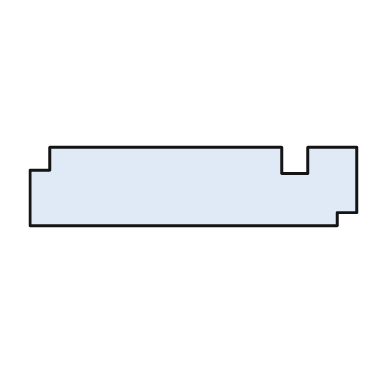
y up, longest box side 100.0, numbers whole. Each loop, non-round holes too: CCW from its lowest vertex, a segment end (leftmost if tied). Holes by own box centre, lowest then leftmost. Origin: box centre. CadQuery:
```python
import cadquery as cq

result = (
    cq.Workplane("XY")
    .moveTo(-50.0, -12.0)
    .lineTo(44.0, -12.0)
    .lineTo(44.0, -8.0)
    .lineTo(50.0, -8.0)
    .lineTo(50.0, 12.0)
    .lineTo(35.0, 12.0)
    .lineTo(35.0, 4.0)
    .lineTo(27.0, 4.0)
    .lineTo(27.0, 12.0)
    .lineTo(-44.0, 12.0)
    .lineTo(-44.0, 5.0)
    .lineTo(-50.0, 5.0)
    .close()
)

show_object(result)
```